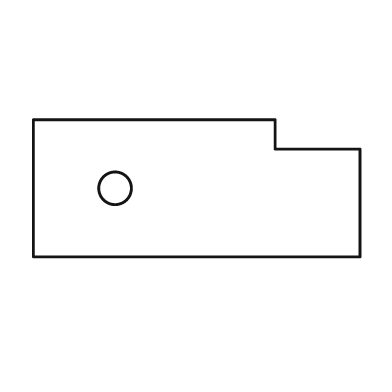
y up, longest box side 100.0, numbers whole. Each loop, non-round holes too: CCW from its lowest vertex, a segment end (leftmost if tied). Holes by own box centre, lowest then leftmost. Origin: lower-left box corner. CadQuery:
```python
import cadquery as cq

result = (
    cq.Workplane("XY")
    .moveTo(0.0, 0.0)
    .lineTo(100.0, 0.0)
    .lineTo(100.0, 33.0)
    .lineTo(74.0, 33.0)
    .lineTo(74.0, 42.0)
    .lineTo(0.0, 42.0)
    .close()
    .moveTo(25.0, 21.0)
    .circle(5.0)
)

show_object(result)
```